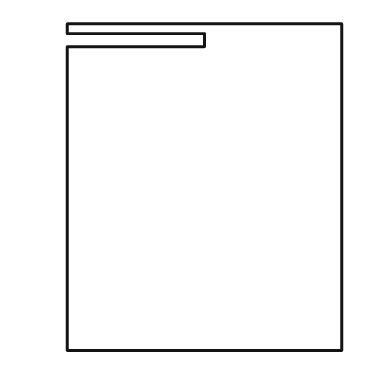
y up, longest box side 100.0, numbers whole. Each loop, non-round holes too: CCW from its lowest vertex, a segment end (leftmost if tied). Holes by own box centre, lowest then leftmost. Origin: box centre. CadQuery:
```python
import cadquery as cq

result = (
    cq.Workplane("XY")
    .moveTo(-42.0, -50.0)
    .lineTo(42.0, -50.0)
    .lineTo(42.0, 50.0)
    .lineTo(-42.0, 50.0)
    .lineTo(-42.0, 47.0)
    .lineTo(0.0, 47.0)
    .lineTo(0.0, 43.0)
    .lineTo(-42.0, 43.0)
    .close()
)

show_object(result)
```